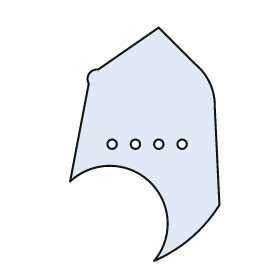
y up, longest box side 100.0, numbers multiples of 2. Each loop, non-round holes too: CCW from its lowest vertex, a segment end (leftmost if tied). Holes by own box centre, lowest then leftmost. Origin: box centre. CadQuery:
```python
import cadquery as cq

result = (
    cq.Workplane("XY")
    .moveTo(4.0, -50.0)
    .threePointArc((20.0, -40.0), (32.0, -26.0))
    .lineTo(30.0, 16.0)
    .threePointArc((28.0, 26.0), (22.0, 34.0))
    .lineTo(6.0, 50.0)
    .lineTo(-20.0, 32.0)
    .threePointArc((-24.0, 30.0), (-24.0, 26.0))
    .lineTo(-32.0, -16.0)
    .threePointArc((2.0, -16.0), (4.0, -50.0))
    .close()
    .moveTo(-14.0, 0.0)
    .circle(2.0)
    .moveTo(-4.0, 0.0)
    .circle(2.0)
    .moveTo(6.0, 0.0)
    .circle(2.0)
    .moveTo(16.0, 0.0)
    .circle(2.0)
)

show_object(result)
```